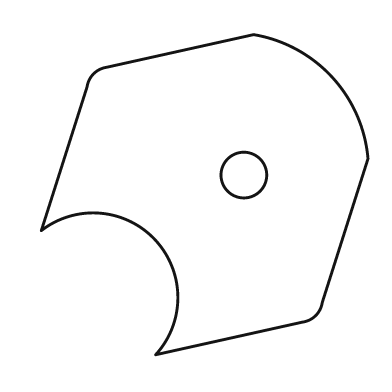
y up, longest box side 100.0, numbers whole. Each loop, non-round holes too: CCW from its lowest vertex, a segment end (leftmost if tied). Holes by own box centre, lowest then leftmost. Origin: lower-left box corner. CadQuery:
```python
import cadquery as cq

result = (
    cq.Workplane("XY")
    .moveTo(35.0, 0.0)
    .lineTo(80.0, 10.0)
    .threePointArc((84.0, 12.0), (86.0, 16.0))
    .lineTo(100.0, 60.0)
    .threePointArc((89.0, 85.0), (65.0, 98.0))
    .lineTo(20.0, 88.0)
    .threePointArc((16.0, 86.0), (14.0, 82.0))
    .lineTo(0.0, 38.0)
    .threePointArc((35.0, 35.0), (35.0, 0.0))
    .close()
    .moveTo(62.0, 55.0)
    .circle(7.0)
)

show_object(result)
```